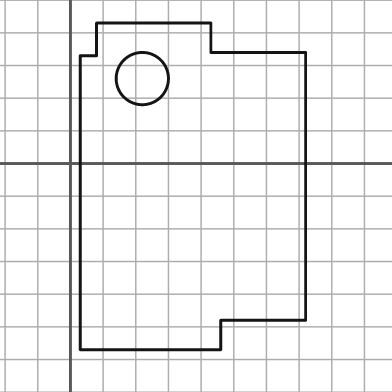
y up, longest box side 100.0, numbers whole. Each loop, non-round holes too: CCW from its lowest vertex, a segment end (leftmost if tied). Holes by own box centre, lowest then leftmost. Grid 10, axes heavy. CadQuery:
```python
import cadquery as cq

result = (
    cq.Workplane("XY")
    .moveTo(3.0, -57.0)
    .lineTo(46.0, -57.0)
    .lineTo(46.0, -48.0)
    .lineTo(72.0, -48.0)
    .lineTo(72.0, 34.0)
    .lineTo(43.0, 34.0)
    .lineTo(43.0, 43.0)
    .lineTo(8.0, 43.0)
    .lineTo(8.0, 33.0)
    .lineTo(3.0, 33.0)
    .close()
    .moveTo(22.0, 26.0)
    .circle(8.0)
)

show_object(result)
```